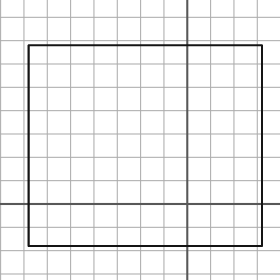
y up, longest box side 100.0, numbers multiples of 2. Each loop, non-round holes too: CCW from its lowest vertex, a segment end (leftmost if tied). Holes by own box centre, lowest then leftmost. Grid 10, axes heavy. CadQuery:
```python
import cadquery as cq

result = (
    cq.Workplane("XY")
    .moveTo(-68.0, -18.0)
    .lineTo(32.0, -18.0)
    .lineTo(32.0, 68.0)
    .lineTo(-68.0, 68.0)
    .close()
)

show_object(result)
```